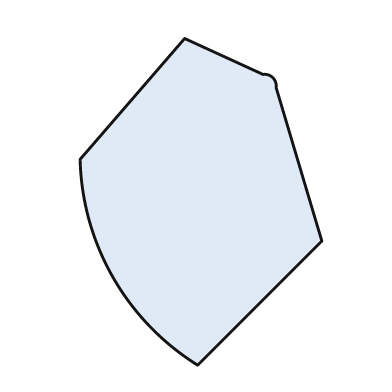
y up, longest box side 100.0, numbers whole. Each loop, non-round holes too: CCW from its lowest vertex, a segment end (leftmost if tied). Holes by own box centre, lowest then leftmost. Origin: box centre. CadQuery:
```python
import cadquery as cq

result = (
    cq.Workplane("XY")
    .moveTo(-1.0, -50.0)
    .lineTo(37.0, -12.0)
    .lineTo(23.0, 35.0)
    .threePointArc((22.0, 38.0), (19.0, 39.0))
    .lineTo(-5.0, 50.0)
    .lineTo(-37.0, 13.0)
    .threePointArc((-27.0, -23.0), (-1.0, -50.0))
    .close()
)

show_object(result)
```